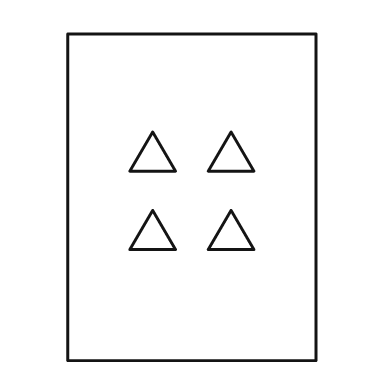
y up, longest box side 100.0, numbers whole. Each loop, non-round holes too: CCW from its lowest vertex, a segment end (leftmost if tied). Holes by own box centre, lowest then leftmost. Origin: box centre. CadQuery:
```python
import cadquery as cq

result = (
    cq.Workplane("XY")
    .moveTo(-38.0, -50.0)
    .lineTo(38.0, -50.0)
    .lineTo(38.0, 50.0)
    .lineTo(-38.0, 50.0)
    .close()
    .moveTo(-19.0, -16.0)
    .lineTo(-5.0, -16.0)
    .lineTo(-12.0, -4.0)
    .close()
    .moveTo(5.0, -16.0)
    .lineTo(19.0, -16.0)
    .lineTo(12.0, -4.0)
    .close()
    .moveTo(-19.0, 8.0)
    .lineTo(-5.0, 8.0)
    .lineTo(-12.0, 20.0)
    .close()
    .moveTo(5.0, 8.0)
    .lineTo(19.0, 8.0)
    .lineTo(12.0, 20.0)
    .close()
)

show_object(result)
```